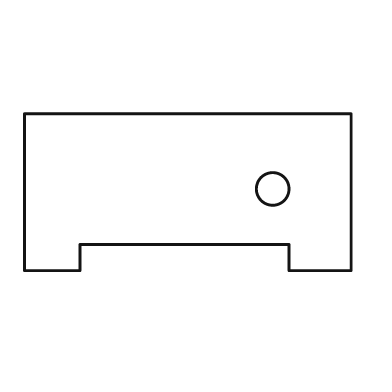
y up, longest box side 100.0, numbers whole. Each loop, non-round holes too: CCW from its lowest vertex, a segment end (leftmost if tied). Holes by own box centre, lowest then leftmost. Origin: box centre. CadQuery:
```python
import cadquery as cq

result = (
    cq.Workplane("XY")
    .moveTo(-50.0, -24.0)
    .lineTo(-33.0, -24.0)
    .lineTo(-33.0, -16.0)
    .lineTo(31.0, -16.0)
    .lineTo(31.0, -24.0)
    .lineTo(50.0, -24.0)
    .lineTo(50.0, 24.0)
    .lineTo(-50.0, 24.0)
    .close()
    .moveTo(26.0, 1.0)
    .circle(5.0)
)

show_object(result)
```